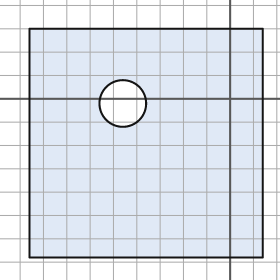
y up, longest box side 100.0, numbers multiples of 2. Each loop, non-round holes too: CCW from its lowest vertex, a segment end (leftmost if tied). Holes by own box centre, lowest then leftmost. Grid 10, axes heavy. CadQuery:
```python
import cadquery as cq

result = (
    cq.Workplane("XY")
    .moveTo(-86.0, -68.0)
    .lineTo(14.0, -68.0)
    .lineTo(14.0, 30.0)
    .lineTo(-86.0, 30.0)
    .close()
    .moveTo(-46.0, -2.0)
    .circle(10.0)
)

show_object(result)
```